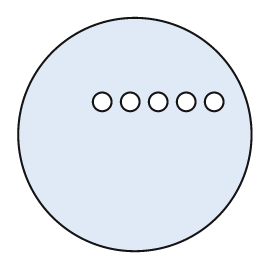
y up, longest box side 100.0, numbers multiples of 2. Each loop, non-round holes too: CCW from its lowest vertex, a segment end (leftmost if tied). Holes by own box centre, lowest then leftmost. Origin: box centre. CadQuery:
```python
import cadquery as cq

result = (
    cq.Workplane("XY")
    .moveTo(0.0, 0.0)
    .circle(50.0)
    .moveTo(-14.0, 14.0)
    .circle(4.0)
    .moveTo(-2.0, 14.0)
    .circle(4.0)
    .moveTo(10.0, 14.0)
    .circle(4.0)
    .moveTo(22.0, 14.0)
    .circle(4.0)
    .moveTo(34.0, 14.0)
    .circle(4.0)
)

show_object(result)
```